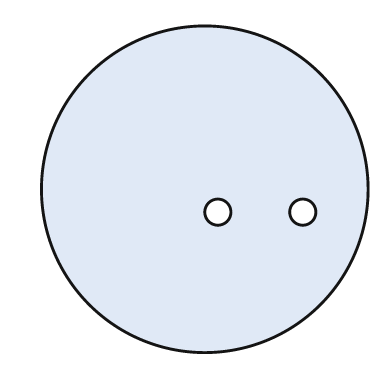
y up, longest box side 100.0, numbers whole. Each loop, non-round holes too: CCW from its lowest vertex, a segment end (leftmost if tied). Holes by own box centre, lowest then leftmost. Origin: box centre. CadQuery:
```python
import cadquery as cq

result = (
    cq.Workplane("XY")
    .moveTo(0.0, 0.0)
    .circle(50.0)
    .moveTo(4.0, -7.0)
    .circle(4.0)
    .moveTo(30.0, -7.0)
    .circle(4.0)
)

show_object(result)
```